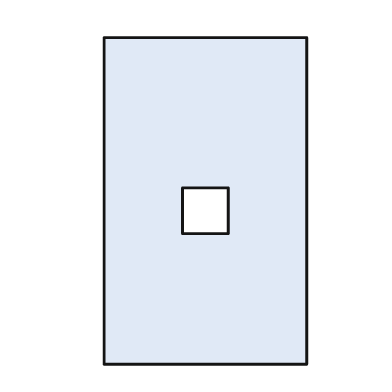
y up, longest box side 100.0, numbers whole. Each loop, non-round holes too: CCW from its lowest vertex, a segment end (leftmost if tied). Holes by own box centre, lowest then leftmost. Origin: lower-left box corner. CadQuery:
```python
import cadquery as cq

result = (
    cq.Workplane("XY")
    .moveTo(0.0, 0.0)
    .lineTo(62.0, 0.0)
    .lineTo(62.0, 100.0)
    .lineTo(0.0, 100.0)
    .close()
    .moveTo(24.0, 40.0)
    .lineTo(38.0, 40.0)
    .lineTo(38.0, 54.0)
    .lineTo(24.0, 54.0)
    .close()
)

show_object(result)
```